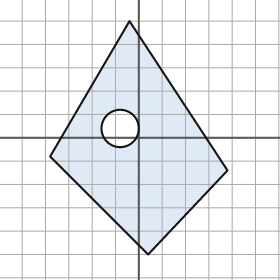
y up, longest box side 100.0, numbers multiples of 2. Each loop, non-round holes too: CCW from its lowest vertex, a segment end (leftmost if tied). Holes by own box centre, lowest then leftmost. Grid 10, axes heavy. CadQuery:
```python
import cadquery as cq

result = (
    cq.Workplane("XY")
    .moveTo(4.0, -50.0)
    .lineTo(38.0, -14.0)
    .lineTo(-4.0, 50.0)
    .lineTo(-38.0, -8.0)
    .close()
    .moveTo(-8.0, 4.0)
    .circle(8.0)
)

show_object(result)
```